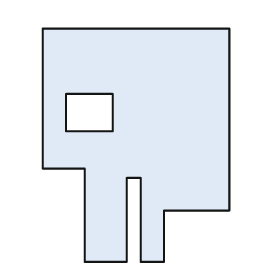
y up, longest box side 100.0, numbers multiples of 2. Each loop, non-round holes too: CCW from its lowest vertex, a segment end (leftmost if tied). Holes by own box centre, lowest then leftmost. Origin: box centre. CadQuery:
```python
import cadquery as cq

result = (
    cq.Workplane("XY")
    .moveTo(-22.0, -50.0)
    .lineTo(-4.0, -50.0)
    .lineTo(-4.0, -14.0)
    .lineTo(2.0, -14.0)
    .lineTo(2.0, -50.0)
    .lineTo(12.0, -50.0)
    .lineTo(12.0, -28.0)
    .lineTo(40.0, -28.0)
    .lineTo(40.0, 50.0)
    .lineTo(-40.0, 50.0)
    .lineTo(-40.0, -10.0)
    .lineTo(-22.0, -10.0)
    .close()
    .moveTo(-30.0, 6.0)
    .lineTo(-10.0, 6.0)
    .lineTo(-10.0, 22.0)
    .lineTo(-30.0, 22.0)
    .close()
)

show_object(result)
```